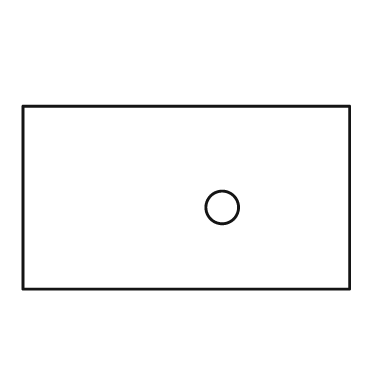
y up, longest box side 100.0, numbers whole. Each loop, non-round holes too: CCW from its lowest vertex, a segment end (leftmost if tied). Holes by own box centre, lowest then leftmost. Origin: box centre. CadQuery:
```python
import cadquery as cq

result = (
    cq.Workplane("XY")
    .moveTo(-50.0, -28.0)
    .lineTo(50.0, -28.0)
    .lineTo(50.0, 28.0)
    .lineTo(-50.0, 28.0)
    .close()
    .moveTo(11.0, -3.0)
    .circle(5.0)
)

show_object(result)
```